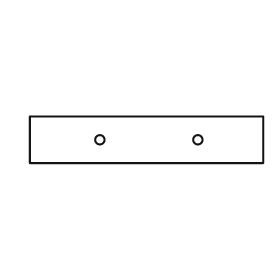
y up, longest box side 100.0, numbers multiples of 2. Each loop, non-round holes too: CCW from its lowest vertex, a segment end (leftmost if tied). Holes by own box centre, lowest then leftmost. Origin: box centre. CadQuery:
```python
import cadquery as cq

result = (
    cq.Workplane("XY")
    .moveTo(-50.0, -10.0)
    .lineTo(50.0, -10.0)
    .lineTo(50.0, 10.0)
    .lineTo(-50.0, 10.0)
    .close()
    .moveTo(-20.0, 0.0)
    .circle(2.0)
    .moveTo(22.0, 0.0)
    .circle(2.0)
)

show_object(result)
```